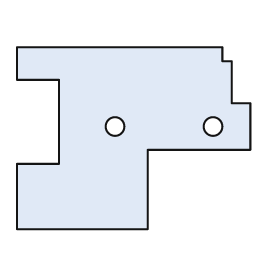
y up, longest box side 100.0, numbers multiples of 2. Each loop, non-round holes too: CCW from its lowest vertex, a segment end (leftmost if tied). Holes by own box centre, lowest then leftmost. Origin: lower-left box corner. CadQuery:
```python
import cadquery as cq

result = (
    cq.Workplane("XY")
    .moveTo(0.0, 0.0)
    .lineTo(56.0, 0.0)
    .lineTo(56.0, 34.0)
    .lineTo(100.0, 34.0)
    .lineTo(100.0, 54.0)
    .lineTo(92.0, 54.0)
    .lineTo(92.0, 72.0)
    .lineTo(88.0, 72.0)
    .lineTo(88.0, 78.0)
    .lineTo(0.0, 78.0)
    .lineTo(0.0, 64.0)
    .lineTo(18.0, 64.0)
    .lineTo(18.0, 28.0)
    .lineTo(0.0, 28.0)
    .close()
    .moveTo(42.0, 44.0)
    .circle(4.0)
    .moveTo(84.0, 44.0)
    .circle(4.0)
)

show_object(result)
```